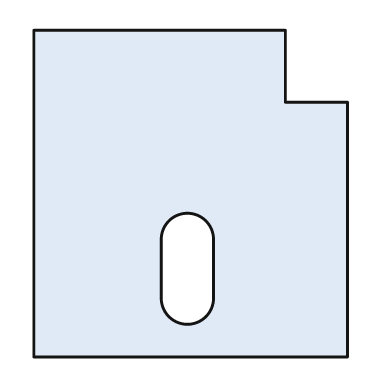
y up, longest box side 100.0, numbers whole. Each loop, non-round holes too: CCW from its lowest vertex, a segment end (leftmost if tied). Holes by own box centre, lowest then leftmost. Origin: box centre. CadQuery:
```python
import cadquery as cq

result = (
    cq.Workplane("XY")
    .moveTo(-48.0, -50.0)
    .lineTo(48.0, -50.0)
    .lineTo(48.0, 28.0)
    .lineTo(29.0, 28.0)
    .lineTo(29.0, 50.0)
    .lineTo(-48.0, 50.0)
    .close()
    .moveTo(-9.0, -32.0)
    .threePointArc((-1.0, -40.0), (7.0, -32.0))
    .lineTo(7.0, -14.0)
    .threePointArc((-1.0, -6.0), (-9.0, -14.0))
    .close()
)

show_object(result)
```